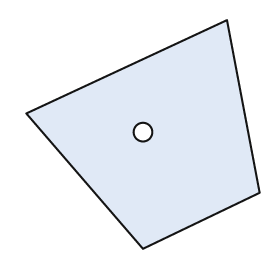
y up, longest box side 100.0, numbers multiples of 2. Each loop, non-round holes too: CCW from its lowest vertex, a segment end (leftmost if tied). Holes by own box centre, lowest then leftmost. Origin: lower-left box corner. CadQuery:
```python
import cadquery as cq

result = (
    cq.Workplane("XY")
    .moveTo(50.0, 0.0)
    .lineTo(100.0, 24.0)
    .lineTo(86.0, 98.0)
    .lineTo(0.0, 58.0)
    .close()
    .moveTo(50.0, 50.0)
    .circle(4.0)
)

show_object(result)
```